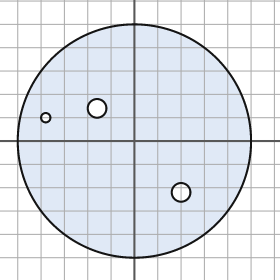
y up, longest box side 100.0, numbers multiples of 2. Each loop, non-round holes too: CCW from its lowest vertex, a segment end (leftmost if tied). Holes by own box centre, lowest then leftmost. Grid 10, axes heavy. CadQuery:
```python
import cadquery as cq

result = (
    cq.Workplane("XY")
    .moveTo(0.0, 0.0)
    .circle(50.0)
    .moveTo(20.0, -22.0)
    .circle(4.0)
    .moveTo(-38.0, 10.0)
    .circle(2.0)
    .moveTo(-16.0, 14.0)
    .circle(4.0)
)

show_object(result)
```